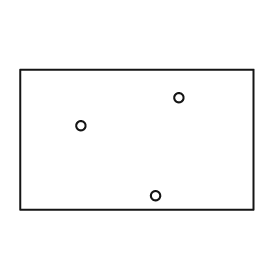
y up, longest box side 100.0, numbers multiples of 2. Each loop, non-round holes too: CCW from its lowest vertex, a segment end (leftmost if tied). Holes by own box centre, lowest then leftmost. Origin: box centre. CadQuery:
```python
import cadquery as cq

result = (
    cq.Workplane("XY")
    .moveTo(-50.0, -30.0)
    .lineTo(50.0, -30.0)
    .lineTo(50.0, 30.0)
    .lineTo(-50.0, 30.0)
    .close()
    .moveTo(8.0, -24.0)
    .circle(2.0)
    .moveTo(-24.0, 6.0)
    .circle(2.0)
    .moveTo(18.0, 18.0)
    .circle(2.0)
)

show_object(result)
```